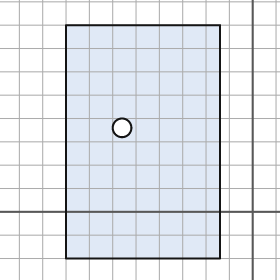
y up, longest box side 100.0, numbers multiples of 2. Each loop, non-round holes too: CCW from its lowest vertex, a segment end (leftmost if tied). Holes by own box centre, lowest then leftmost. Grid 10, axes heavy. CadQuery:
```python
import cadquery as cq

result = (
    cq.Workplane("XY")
    .moveTo(-80.0, -20.0)
    .lineTo(-14.0, -20.0)
    .lineTo(-14.0, 80.0)
    .lineTo(-80.0, 80.0)
    .close()
    .moveTo(-56.0, 36.0)
    .circle(4.0)
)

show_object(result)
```